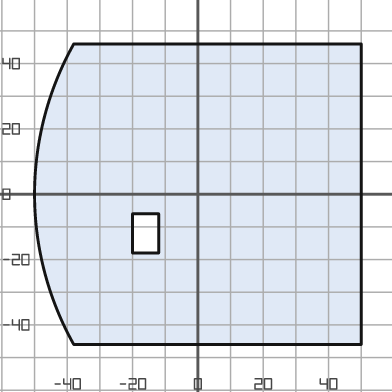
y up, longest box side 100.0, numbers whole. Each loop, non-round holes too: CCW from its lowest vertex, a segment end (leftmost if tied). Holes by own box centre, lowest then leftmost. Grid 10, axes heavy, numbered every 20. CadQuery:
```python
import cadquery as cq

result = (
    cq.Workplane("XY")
    .moveTo(-38.0, -46.0)
    .lineTo(50.0, -46.0)
    .lineTo(50.0, 46.0)
    .lineTo(-38.0, 46.0)
    .threePointArc((-50.0, 0.0), (-38.0, -46.0))
    .close()
    .moveTo(-20.0, -18.0)
    .lineTo(-12.0, -18.0)
    .lineTo(-12.0, -6.0)
    .lineTo(-20.0, -6.0)
    .close()
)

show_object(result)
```